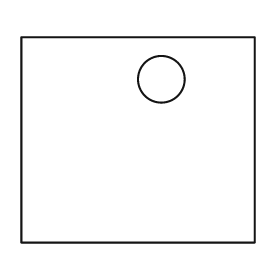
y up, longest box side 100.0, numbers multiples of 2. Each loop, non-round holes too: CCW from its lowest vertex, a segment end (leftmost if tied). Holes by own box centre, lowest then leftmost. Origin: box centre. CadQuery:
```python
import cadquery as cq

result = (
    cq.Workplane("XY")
    .moveTo(-50.0, -44.0)
    .lineTo(50.0, -44.0)
    .lineTo(50.0, 44.0)
    .lineTo(-50.0, 44.0)
    .close()
    .moveTo(10.0, 26.0)
    .circle(10.0)
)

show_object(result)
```